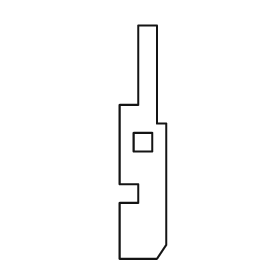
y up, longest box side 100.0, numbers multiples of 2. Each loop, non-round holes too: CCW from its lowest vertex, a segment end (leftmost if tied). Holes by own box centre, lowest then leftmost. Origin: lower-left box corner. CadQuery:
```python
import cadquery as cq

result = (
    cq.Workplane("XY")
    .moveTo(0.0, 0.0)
    .lineTo(16.0, 0.0)
    .lineTo(20.0, 6.0)
    .lineTo(20.0, 58.0)
    .lineTo(16.0, 58.0)
    .lineTo(16.0, 100.0)
    .lineTo(8.0, 100.0)
    .lineTo(8.0, 66.0)
    .lineTo(0.0, 66.0)
    .lineTo(0.0, 32.0)
    .lineTo(8.0, 32.0)
    .lineTo(8.0, 24.0)
    .lineTo(0.0, 24.0)
    .close()
    .moveTo(6.0, 46.0)
    .lineTo(14.0, 46.0)
    .lineTo(14.0, 54.0)
    .lineTo(6.0, 54.0)
    .close()
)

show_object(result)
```